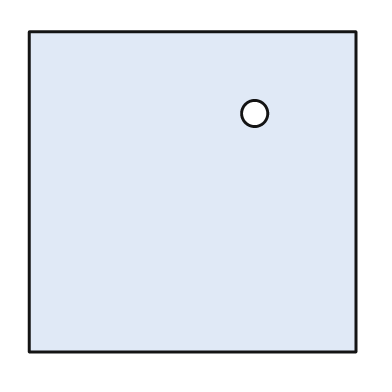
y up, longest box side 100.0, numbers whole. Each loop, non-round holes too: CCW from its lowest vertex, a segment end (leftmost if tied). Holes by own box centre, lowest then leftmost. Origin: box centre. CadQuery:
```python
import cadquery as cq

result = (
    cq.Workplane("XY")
    .moveTo(-50.0, -49.0)
    .lineTo(50.0, -49.0)
    .lineTo(50.0, 49.0)
    .lineTo(-50.0, 49.0)
    .close()
    .moveTo(19.0, 24.0)
    .circle(4.0)
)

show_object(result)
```